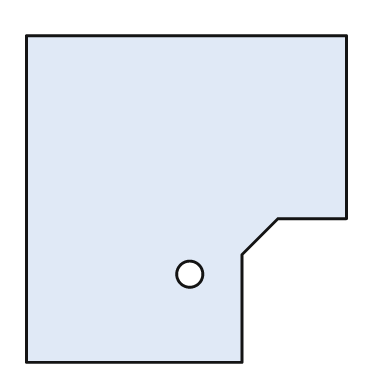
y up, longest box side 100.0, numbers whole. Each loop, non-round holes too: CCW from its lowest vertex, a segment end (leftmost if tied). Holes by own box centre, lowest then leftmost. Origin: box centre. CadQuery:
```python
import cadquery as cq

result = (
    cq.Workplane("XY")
    .moveTo(-49.0, -50.0)
    .lineTo(17.0, -50.0)
    .lineTo(17.0, -17.0)
    .lineTo(28.0, -6.0)
    .lineTo(49.0, -6.0)
    .lineTo(49.0, 50.0)
    .lineTo(-49.0, 50.0)
    .close()
    .moveTo(1.0, -23.0)
    .circle(4.0)
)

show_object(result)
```